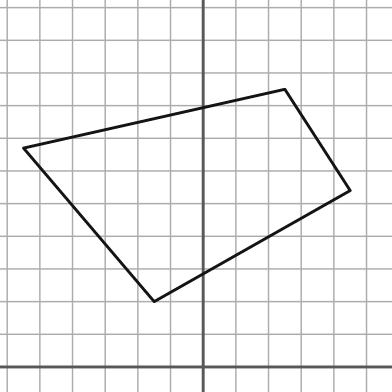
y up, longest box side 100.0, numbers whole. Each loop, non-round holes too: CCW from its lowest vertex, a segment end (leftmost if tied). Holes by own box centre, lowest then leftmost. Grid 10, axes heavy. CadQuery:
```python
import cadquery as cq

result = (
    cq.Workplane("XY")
    .moveTo(-15.0, 20.0)
    .lineTo(45.0, 54.0)
    .lineTo(25.0, 85.0)
    .lineTo(-55.0, 67.0)
    .close()
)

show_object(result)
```